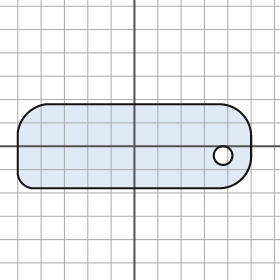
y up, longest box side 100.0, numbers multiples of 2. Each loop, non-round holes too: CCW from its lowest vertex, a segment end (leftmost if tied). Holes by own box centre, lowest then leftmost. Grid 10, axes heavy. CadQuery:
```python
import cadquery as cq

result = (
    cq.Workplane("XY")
    .moveTo(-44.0, -18.0)
    .lineTo(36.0, -18.0)
    .threePointArc((46.0, -14.0), (50.0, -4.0))
    .lineTo(50.0, 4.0)
    .threePointArc((46.0, 14.0), (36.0, 18.0))
    .lineTo(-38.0, 18.0)
    .threePointArc((-46.0, 14.0), (-50.0, 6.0))
    .lineTo(-50.0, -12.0)
    .threePointArc((-48.0, -16.0), (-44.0, -18.0))
    .close()
    .moveTo(38.0, -4.0)
    .circle(4.0)
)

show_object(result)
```